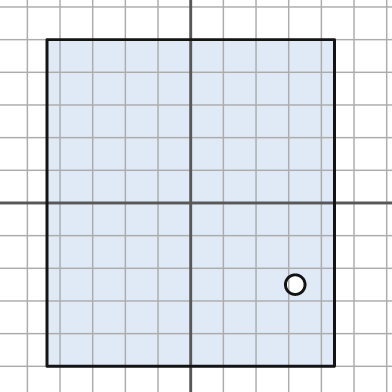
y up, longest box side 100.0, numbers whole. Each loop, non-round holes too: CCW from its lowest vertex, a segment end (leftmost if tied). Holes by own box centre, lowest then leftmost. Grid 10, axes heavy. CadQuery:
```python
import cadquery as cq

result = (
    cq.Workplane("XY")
    .moveTo(-44.0, -50.0)
    .lineTo(44.0, -50.0)
    .lineTo(44.0, 50.0)
    .lineTo(-44.0, 50.0)
    .close()
    .moveTo(32.0, -25.0)
    .circle(3.0)
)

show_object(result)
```